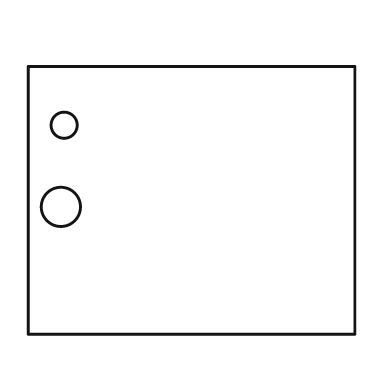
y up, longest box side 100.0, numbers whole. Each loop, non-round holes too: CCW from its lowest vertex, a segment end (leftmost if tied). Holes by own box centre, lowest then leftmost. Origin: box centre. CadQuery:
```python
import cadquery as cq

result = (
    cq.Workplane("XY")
    .moveTo(-50.0, -41.0)
    .lineTo(50.0, -41.0)
    .lineTo(50.0, 41.0)
    .lineTo(-50.0, 41.0)
    .close()
    .moveTo(-40.0, -2.0)
    .circle(6.0)
    .moveTo(-39.0, 23.0)
    .circle(4.0)
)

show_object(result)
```